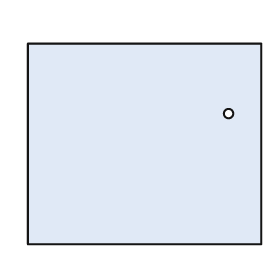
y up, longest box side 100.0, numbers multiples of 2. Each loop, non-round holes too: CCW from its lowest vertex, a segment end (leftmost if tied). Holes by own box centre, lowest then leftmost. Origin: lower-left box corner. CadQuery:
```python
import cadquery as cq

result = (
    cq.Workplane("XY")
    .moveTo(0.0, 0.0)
    .lineTo(100.0, 0.0)
    .lineTo(100.0, 86.0)
    .lineTo(0.0, 86.0)
    .close()
    .moveTo(86.0, 56.0)
    .circle(2.0)
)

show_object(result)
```